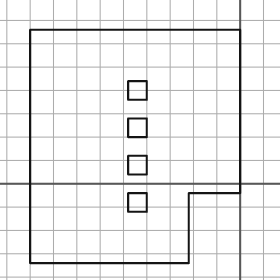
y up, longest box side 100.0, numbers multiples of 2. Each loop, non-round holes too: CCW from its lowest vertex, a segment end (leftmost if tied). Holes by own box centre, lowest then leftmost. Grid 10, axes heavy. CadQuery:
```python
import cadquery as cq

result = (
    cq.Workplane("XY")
    .moveTo(-90.0, -34.0)
    .lineTo(-22.0, -34.0)
    .lineTo(-22.0, -4.0)
    .lineTo(0.0, -4.0)
    .lineTo(0.0, 66.0)
    .lineTo(-90.0, 66.0)
    .close()
    .moveTo(-48.0, -12.0)
    .lineTo(-40.0, -12.0)
    .lineTo(-40.0, -4.0)
    .lineTo(-48.0, -4.0)
    .close()
    .moveTo(-48.0, 4.0)
    .lineTo(-40.0, 4.0)
    .lineTo(-40.0, 12.0)
    .lineTo(-48.0, 12.0)
    .close()
    .moveTo(-48.0, 20.0)
    .lineTo(-40.0, 20.0)
    .lineTo(-40.0, 28.0)
    .lineTo(-48.0, 28.0)
    .close()
    .moveTo(-48.0, 36.0)
    .lineTo(-40.0, 36.0)
    .lineTo(-40.0, 44.0)
    .lineTo(-48.0, 44.0)
    .close()
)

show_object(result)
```